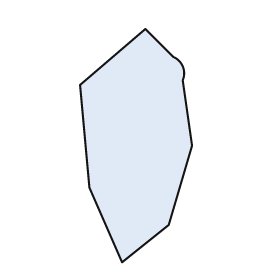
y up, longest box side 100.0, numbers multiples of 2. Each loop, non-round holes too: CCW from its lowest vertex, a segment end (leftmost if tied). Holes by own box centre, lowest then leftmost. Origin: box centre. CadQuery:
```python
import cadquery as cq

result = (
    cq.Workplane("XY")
    .moveTo(-6.0, -50.0)
    .lineTo(14.0, -34.0)
    .lineTo(24.0, 0.0)
    .lineTo(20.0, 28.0)
    .threePointArc((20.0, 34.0), (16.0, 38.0))
    .lineTo(4.0, 50.0)
    .lineTo(-24.0, 26.0)
    .lineTo(-20.0, -18.0)
    .close()
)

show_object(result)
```